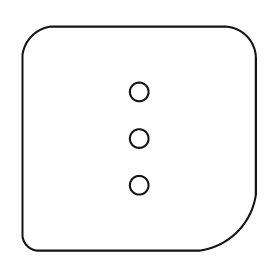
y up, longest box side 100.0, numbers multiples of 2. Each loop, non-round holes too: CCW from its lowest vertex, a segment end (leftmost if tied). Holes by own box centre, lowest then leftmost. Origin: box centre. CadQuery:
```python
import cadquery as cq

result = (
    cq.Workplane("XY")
    .moveTo(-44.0, -48.0)
    .lineTo(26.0, -48.0)
    .threePointArc((42.0, -40.0), (50.0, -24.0))
    .lineTo(50.0, 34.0)
    .threePointArc((46.0, 44.0), (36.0, 48.0))
    .lineTo(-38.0, 48.0)
    .threePointArc((-46.0, 44.0), (-50.0, 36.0))
    .lineTo(-50.0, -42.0)
    .threePointArc((-48.0, -46.0), (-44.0, -48.0))
    .close()
    .moveTo(0.0, -20.0)
    .circle(4.0)
    .moveTo(0.0, 0.0)
    .circle(4.0)
    .moveTo(0.0, 20.0)
    .circle(4.0)
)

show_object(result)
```